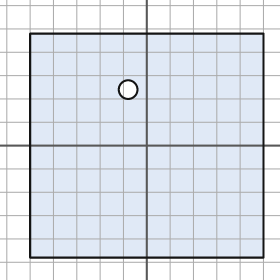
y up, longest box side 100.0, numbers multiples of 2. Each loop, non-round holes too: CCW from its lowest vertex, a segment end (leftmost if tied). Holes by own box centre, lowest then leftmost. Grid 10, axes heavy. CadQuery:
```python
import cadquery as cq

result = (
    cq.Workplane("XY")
    .moveTo(-50.0, -48.0)
    .lineTo(50.0, -48.0)
    .lineTo(50.0, 48.0)
    .lineTo(-50.0, 48.0)
    .close()
    .moveTo(-8.0, 24.0)
    .circle(4.0)
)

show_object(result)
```